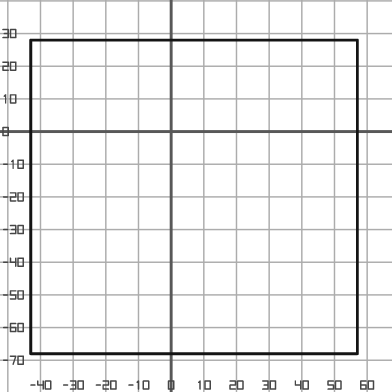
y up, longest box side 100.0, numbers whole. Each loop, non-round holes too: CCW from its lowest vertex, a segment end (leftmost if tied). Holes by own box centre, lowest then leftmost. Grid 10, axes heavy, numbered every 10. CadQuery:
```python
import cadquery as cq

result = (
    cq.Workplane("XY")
    .moveTo(-43.0, -68.0)
    .lineTo(57.0, -68.0)
    .lineTo(57.0, 28.0)
    .lineTo(-43.0, 28.0)
    .close()
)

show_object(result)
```